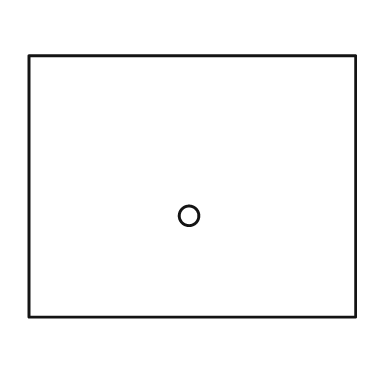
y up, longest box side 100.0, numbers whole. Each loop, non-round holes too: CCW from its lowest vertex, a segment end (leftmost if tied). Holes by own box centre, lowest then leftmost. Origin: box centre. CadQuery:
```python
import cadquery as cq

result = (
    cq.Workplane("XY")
    .moveTo(-50.0, -40.0)
    .lineTo(50.0, -40.0)
    .lineTo(50.0, 40.0)
    .lineTo(-50.0, 40.0)
    .close()
    .moveTo(-1.0, -9.0)
    .circle(3.0)
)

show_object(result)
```